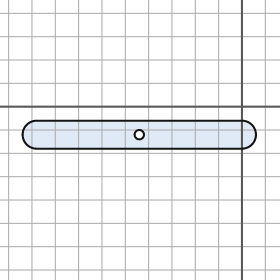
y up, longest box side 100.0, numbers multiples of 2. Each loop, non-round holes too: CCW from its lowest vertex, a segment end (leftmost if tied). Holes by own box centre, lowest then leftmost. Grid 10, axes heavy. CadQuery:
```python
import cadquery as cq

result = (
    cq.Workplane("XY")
    .moveTo(-88.0, -18.0)
    .lineTo(0.0, -18.0)
    .threePointArc((6.0, -12.0), (0.0, -6.0))
    .lineTo(-88.0, -6.0)
    .threePointArc((-94.0, -12.0), (-88.0, -18.0))
    .close()
    .moveTo(-44.0, -12.0)
    .circle(2.0)
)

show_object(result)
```